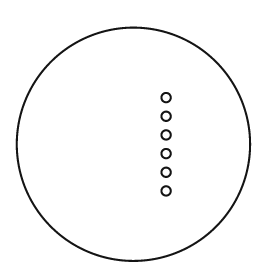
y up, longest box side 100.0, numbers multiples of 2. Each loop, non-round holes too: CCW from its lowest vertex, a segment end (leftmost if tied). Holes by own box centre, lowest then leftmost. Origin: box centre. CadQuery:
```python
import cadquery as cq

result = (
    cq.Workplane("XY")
    .moveTo(0.0, 0.0)
    .circle(50.0)
    .moveTo(14.0, -20.0)
    .circle(2.0)
    .moveTo(14.0, -12.0)
    .circle(2.0)
    .moveTo(14.0, -4.0)
    .circle(2.0)
    .moveTo(14.0, 4.0)
    .circle(2.0)
    .moveTo(14.0, 12.0)
    .circle(2.0)
    .moveTo(14.0, 20.0)
    .circle(2.0)
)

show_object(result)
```